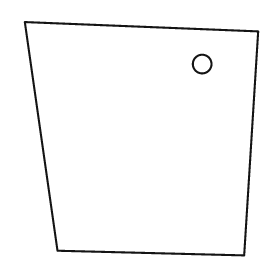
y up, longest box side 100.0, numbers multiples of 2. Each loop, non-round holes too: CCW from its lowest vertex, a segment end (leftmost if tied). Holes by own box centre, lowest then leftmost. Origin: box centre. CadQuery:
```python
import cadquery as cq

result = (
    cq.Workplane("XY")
    .moveTo(44.0, -50.0)
    .lineTo(50.0, 46.0)
    .lineTo(-50.0, 50.0)
    .lineTo(-36.0, -48.0)
    .close()
    .moveTo(26.0, 32.0)
    .circle(4.0)
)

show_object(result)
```